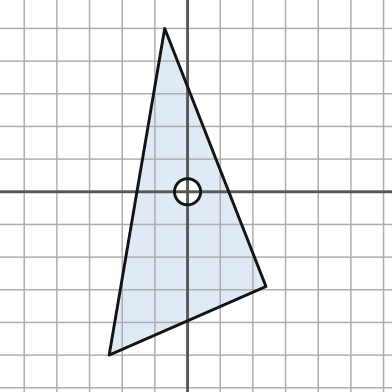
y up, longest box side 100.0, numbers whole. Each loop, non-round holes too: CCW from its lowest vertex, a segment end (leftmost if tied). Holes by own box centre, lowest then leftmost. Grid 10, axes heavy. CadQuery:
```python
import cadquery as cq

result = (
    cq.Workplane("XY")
    .moveTo(-24.0, -50.0)
    .lineTo(24.0, -29.0)
    .lineTo(-7.0, 50.0)
    .close()
    .moveTo(0.0, 0.0)
    .circle(4.0)
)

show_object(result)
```